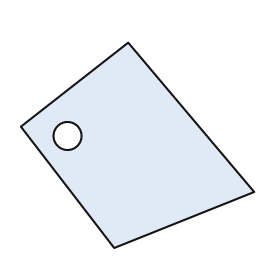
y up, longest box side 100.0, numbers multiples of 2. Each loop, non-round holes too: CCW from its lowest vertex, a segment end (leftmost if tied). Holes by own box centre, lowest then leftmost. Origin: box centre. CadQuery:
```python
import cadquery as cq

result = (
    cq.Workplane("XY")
    .moveTo(-10.0, -44.0)
    .lineTo(50.0, -20.0)
    .lineTo(-4.0, 44.0)
    .lineTo(-50.0, 8.0)
    .close()
    .moveTo(-30.0, 4.0)
    .circle(6.0)
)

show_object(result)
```